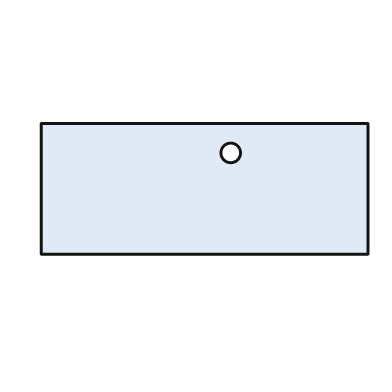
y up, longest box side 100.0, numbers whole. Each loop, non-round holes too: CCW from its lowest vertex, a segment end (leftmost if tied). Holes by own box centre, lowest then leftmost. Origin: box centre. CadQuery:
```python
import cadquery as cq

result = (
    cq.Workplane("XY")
    .moveTo(-50.0, -20.0)
    .lineTo(50.0, -20.0)
    .lineTo(50.0, 20.0)
    .lineTo(-50.0, 20.0)
    .close()
    .moveTo(8.0, 11.0)
    .circle(3.0)
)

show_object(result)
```